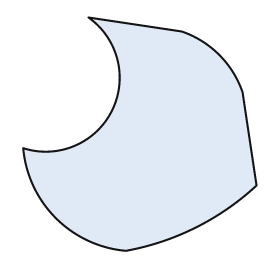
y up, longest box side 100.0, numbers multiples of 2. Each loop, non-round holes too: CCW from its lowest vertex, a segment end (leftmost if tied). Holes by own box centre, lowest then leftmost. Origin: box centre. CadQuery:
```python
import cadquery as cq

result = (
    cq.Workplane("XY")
    .moveTo(-6.0, -50.0)
    .threePointArc((24.0, -40.0), (50.0, -22.0))
    .lineTo(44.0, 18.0)
    .threePointArc((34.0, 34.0), (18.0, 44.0))
    .lineTo(-22.0, 50.0)
    .threePointArc((-12.0, 10.0), (-50.0, -6.0))
    .threePointArc((-36.0, -36.0), (-6.0, -50.0))
    .close()
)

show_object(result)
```